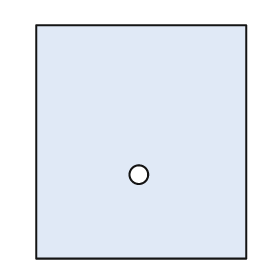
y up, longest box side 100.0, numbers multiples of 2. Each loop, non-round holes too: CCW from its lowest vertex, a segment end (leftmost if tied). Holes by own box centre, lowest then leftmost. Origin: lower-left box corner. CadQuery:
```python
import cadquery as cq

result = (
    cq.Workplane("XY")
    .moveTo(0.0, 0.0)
    .lineTo(90.0, 0.0)
    .lineTo(90.0, 100.0)
    .lineTo(0.0, 100.0)
    .close()
    .moveTo(44.0, 36.0)
    .circle(4.0)
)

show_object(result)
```